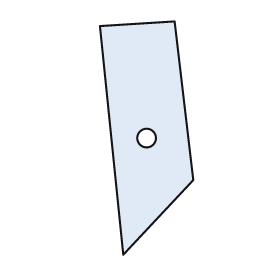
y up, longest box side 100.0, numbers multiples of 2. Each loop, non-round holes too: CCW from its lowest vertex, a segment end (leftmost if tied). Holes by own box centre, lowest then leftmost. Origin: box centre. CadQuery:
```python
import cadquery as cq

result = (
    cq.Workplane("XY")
    .moveTo(-10.0, -50.0)
    .lineTo(20.0, -18.0)
    .lineTo(12.0, 50.0)
    .lineTo(-20.0, 48.0)
    .close()
    .moveTo(0.0, 0.0)
    .circle(4.0)
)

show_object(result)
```